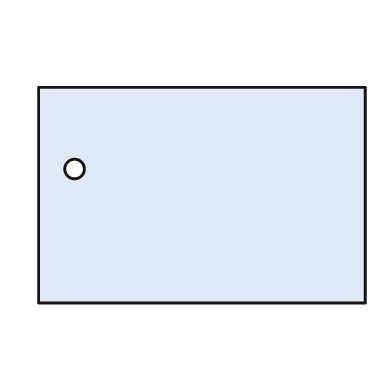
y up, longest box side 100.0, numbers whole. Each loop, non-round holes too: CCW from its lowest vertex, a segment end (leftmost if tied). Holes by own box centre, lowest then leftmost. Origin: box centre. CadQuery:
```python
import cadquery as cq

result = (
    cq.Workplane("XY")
    .moveTo(-50.0, -33.0)
    .lineTo(50.0, -33.0)
    .lineTo(50.0, 33.0)
    .lineTo(-50.0, 33.0)
    .close()
    .moveTo(-39.0, 8.0)
    .circle(3.0)
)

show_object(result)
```